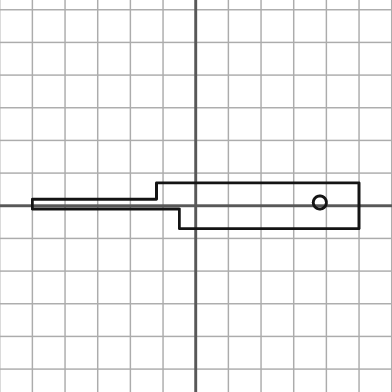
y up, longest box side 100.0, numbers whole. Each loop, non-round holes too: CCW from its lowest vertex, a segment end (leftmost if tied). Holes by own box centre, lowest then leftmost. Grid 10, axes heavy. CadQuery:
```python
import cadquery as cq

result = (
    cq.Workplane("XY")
    .moveTo(-5.0, -7.0)
    .lineTo(50.0, -7.0)
    .lineTo(50.0, 7.0)
    .lineTo(-12.0, 7.0)
    .lineTo(-12.0, 2.0)
    .lineTo(-50.0, 2.0)
    .lineTo(-50.0, -1.0)
    .lineTo(-5.0, -1.0)
    .close()
    .moveTo(38.0, 1.0)
    .circle(2.0)
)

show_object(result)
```